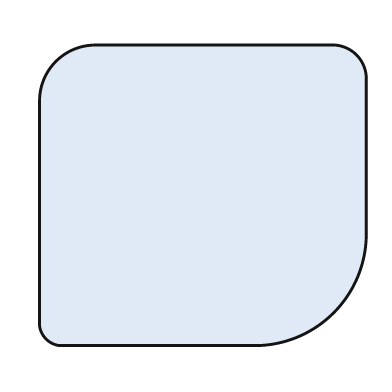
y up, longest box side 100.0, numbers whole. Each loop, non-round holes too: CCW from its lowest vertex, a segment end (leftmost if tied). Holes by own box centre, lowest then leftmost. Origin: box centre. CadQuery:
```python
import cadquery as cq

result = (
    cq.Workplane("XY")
    .moveTo(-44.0, -46.0)
    .lineTo(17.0, -46.0)
    .threePointArc((40.0, -36.0), (50.0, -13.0))
    .lineTo(50.0, 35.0)
    .threePointArc((47.0, 43.0), (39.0, 46.0))
    .lineTo(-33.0, 46.0)
    .threePointArc((-45.0, 41.0), (-50.0, 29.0))
    .lineTo(-50.0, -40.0)
    .threePointArc((-48.0, -44.0), (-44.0, -46.0))
    .close()
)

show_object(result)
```